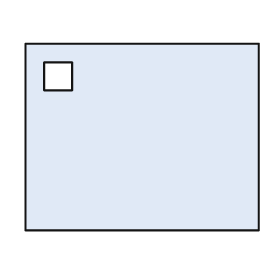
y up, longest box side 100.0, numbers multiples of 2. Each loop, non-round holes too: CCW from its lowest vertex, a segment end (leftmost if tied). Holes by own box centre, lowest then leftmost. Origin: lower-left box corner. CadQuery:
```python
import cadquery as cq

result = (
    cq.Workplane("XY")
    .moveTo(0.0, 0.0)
    .lineTo(100.0, 0.0)
    .lineTo(100.0, 80.0)
    .lineTo(0.0, 80.0)
    .close()
    .moveTo(8.0, 60.0)
    .lineTo(20.0, 60.0)
    .lineTo(20.0, 72.0)
    .lineTo(8.0, 72.0)
    .close()
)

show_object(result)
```